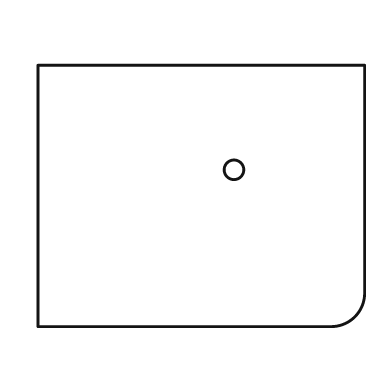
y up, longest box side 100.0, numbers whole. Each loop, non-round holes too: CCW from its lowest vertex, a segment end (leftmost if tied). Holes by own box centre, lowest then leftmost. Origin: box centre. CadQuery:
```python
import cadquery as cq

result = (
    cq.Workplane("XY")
    .moveTo(-50.0, -40.0)
    .lineTo(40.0, -40.0)
    .threePointArc((47.0, -37.0), (50.0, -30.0))
    .lineTo(50.0, 40.0)
    .lineTo(-50.0, 40.0)
    .close()
    .moveTo(10.0, 8.0)
    .circle(3.0)
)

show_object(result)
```